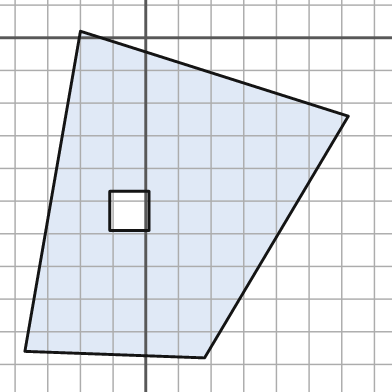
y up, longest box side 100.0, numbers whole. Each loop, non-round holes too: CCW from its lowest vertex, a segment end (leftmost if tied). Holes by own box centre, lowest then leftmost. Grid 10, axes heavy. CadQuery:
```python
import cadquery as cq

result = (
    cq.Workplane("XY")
    .moveTo(18.0, -98.0)
    .lineTo(62.0, -24.0)
    .lineTo(-20.0, 2.0)
    .lineTo(-37.0, -96.0)
    .close()
    .moveTo(-11.0, -59.0)
    .lineTo(1.0, -59.0)
    .lineTo(1.0, -47.0)
    .lineTo(-11.0, -47.0)
    .close()
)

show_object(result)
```